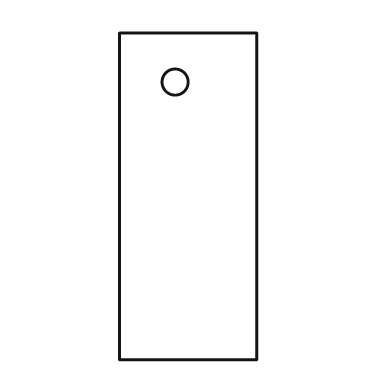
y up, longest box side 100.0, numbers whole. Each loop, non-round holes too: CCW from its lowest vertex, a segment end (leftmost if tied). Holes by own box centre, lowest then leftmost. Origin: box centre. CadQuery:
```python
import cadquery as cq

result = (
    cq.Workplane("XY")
    .moveTo(-21.0, -50.0)
    .lineTo(21.0, -50.0)
    .lineTo(21.0, 50.0)
    .lineTo(-21.0, 50.0)
    .close()
    .moveTo(-4.0, 35.0)
    .circle(4.0)
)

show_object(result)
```